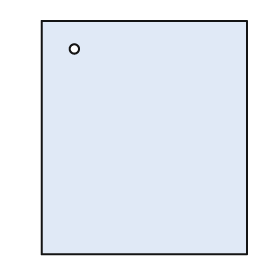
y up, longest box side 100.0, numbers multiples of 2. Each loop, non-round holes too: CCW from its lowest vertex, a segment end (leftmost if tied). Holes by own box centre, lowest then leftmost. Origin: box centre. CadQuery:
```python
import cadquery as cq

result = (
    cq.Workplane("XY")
    .moveTo(-44.0, -50.0)
    .lineTo(44.0, -50.0)
    .lineTo(44.0, 50.0)
    .lineTo(-44.0, 50.0)
    .close()
    .moveTo(-30.0, 38.0)
    .circle(2.0)
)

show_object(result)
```